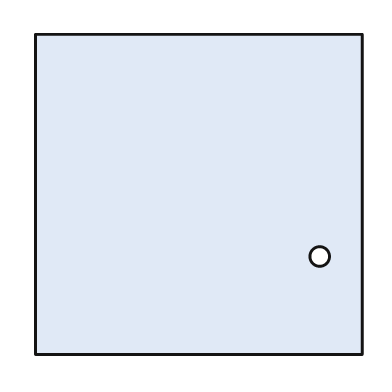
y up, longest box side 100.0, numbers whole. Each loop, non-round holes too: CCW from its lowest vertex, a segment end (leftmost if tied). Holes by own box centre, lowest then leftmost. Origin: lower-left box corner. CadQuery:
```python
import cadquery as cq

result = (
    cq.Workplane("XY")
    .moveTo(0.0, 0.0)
    .lineTo(100.0, 0.0)
    .lineTo(100.0, 98.0)
    .lineTo(0.0, 98.0)
    .close()
    .moveTo(87.0, 30.0)
    .circle(3.0)
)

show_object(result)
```